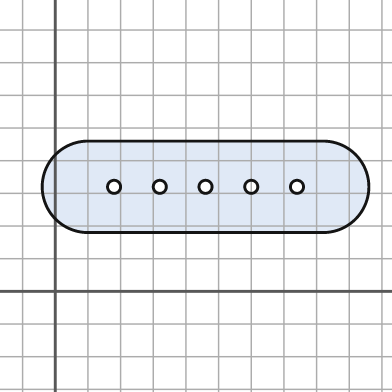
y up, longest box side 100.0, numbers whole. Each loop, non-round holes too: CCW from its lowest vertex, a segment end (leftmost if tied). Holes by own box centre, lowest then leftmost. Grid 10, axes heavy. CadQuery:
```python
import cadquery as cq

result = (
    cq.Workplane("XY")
    .moveTo(10.0, 18.0)
    .lineTo(82.0, 18.0)
    .threePointArc((96.0, 32.0), (82.0, 46.0))
    .lineTo(10.0, 46.0)
    .threePointArc((-4.0, 32.0), (10.0, 18.0))
    .close()
    .moveTo(18.0, 32.0)
    .circle(2.0)
    .moveTo(32.0, 32.0)
    .circle(2.0)
    .moveTo(46.0, 32.0)
    .circle(2.0)
    .moveTo(60.0, 32.0)
    .circle(2.0)
    .moveTo(74.0, 32.0)
    .circle(2.0)
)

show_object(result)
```